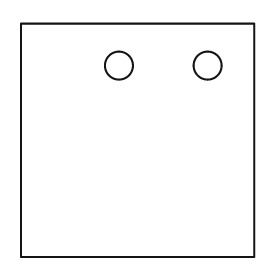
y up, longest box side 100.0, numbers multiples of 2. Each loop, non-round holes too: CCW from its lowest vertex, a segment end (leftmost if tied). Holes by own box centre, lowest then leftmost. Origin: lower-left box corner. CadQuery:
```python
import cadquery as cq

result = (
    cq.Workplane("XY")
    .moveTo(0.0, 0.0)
    .lineTo(100.0, 0.0)
    .lineTo(100.0, 100.0)
    .lineTo(0.0, 100.0)
    .close()
    .moveTo(42.0, 82.0)
    .circle(6.0)
    .moveTo(80.0, 82.0)
    .circle(6.0)
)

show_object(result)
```